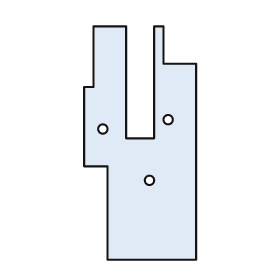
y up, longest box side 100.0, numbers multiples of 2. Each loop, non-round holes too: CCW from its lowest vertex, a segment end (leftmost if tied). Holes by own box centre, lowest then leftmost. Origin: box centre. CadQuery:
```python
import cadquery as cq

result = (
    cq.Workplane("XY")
    .moveTo(-14.0, -50.0)
    .lineTo(24.0, -50.0)
    .lineTo(24.0, 34.0)
    .lineTo(10.0, 34.0)
    .lineTo(10.0, 50.0)
    .lineTo(6.0, 50.0)
    .lineTo(6.0, 2.0)
    .lineTo(-6.0, 2.0)
    .lineTo(-6.0, 50.0)
    .lineTo(-20.0, 50.0)
    .lineTo(-20.0, 24.0)
    .lineTo(-24.0, 24.0)
    .lineTo(-24.0, -10.0)
    .lineTo(-14.0, -10.0)
    .close()
    .moveTo(4.0, -16.0)
    .circle(2.0)
    .moveTo(-16.0, 6.0)
    .circle(2.0)
    .moveTo(12.0, 10.0)
    .circle(2.0)
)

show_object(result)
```